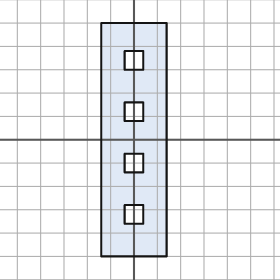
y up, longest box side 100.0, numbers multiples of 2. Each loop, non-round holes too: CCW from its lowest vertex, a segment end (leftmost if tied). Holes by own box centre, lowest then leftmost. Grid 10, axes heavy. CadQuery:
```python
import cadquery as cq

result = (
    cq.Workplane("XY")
    .moveTo(-14.0, -50.0)
    .lineTo(14.0, -50.0)
    .lineTo(14.0, 50.0)
    .lineTo(-14.0, 50.0)
    .close()
    .moveTo(-4.0, -36.0)
    .lineTo(4.0, -36.0)
    .lineTo(4.0, -28.0)
    .lineTo(-4.0, -28.0)
    .close()
    .moveTo(-4.0, -14.0)
    .lineTo(4.0, -14.0)
    .lineTo(4.0, -6.0)
    .lineTo(-4.0, -6.0)
    .close()
    .moveTo(-4.0, 8.0)
    .lineTo(4.0, 8.0)
    .lineTo(4.0, 16.0)
    .lineTo(-4.0, 16.0)
    .close()
    .moveTo(-4.0, 30.0)
    .lineTo(4.0, 30.0)
    .lineTo(4.0, 38.0)
    .lineTo(-4.0, 38.0)
    .close()
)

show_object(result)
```